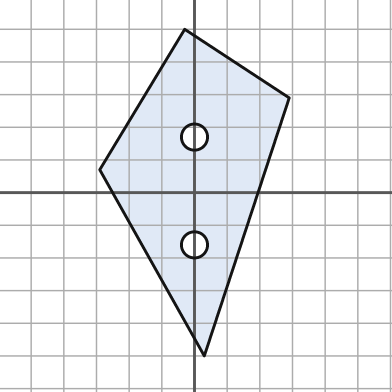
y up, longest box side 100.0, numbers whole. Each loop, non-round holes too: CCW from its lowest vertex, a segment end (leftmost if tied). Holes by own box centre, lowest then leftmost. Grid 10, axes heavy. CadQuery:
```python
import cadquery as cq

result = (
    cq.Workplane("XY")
    .moveTo(3.0, -50.0)
    .lineTo(29.0, 29.0)
    .lineTo(-3.0, 50.0)
    .lineTo(-29.0, 7.0)
    .close()
    .moveTo(0.0, -16.0)
    .circle(4.0)
    .moveTo(0.0, 17.0)
    .circle(4.0)
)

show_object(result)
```